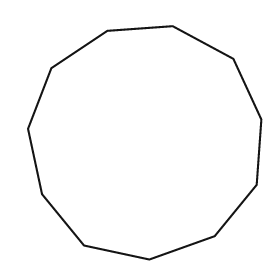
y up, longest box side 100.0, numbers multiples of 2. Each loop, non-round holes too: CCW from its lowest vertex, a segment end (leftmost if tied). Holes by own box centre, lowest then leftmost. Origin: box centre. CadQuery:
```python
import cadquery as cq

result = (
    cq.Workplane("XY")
    .moveTo(2.0, -50.0)
    .lineTo(30.0, -40.0)
    .lineTo(48.0, -18.0)
    .lineTo(50.0, 10.0)
    .lineTo(38.0, 36.0)
    .lineTo(12.0, 50.0)
    .lineTo(-16.0, 48.0)
    .lineTo(-40.0, 32.0)
    .lineTo(-50.0, 6.0)
    .lineTo(-44.0, -22.0)
    .lineTo(-26.0, -44.0)
    .close()
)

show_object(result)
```